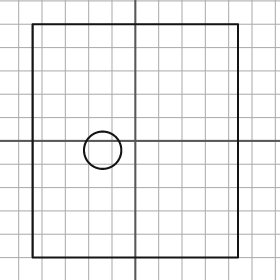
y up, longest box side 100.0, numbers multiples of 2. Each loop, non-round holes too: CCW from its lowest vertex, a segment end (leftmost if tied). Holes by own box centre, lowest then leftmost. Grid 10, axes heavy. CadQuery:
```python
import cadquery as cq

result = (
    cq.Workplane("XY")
    .moveTo(-44.0, -50.0)
    .lineTo(44.0, -50.0)
    .lineTo(44.0, 50.0)
    .lineTo(-44.0, 50.0)
    .close()
    .moveTo(-14.0, -4.0)
    .circle(8.0)
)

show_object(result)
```